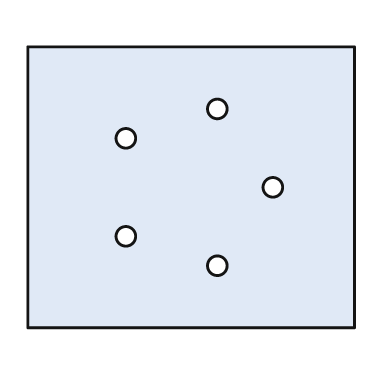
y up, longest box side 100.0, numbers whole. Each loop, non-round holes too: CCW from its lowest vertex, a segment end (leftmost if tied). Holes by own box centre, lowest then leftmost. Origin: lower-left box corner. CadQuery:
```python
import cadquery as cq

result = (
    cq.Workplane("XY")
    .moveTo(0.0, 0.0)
    .lineTo(100.0, 0.0)
    .lineTo(100.0, 86.0)
    .lineTo(0.0, 86.0)
    .close()
    .moveTo(58.0, 19.0)
    .circle(3.0)
    .moveTo(30.0, 28.0)
    .circle(3.0)
    .moveTo(75.0, 43.0)
    .circle(3.0)
    .moveTo(30.0, 58.0)
    .circle(3.0)
    .moveTo(58.0, 67.0)
    .circle(3.0)
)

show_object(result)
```